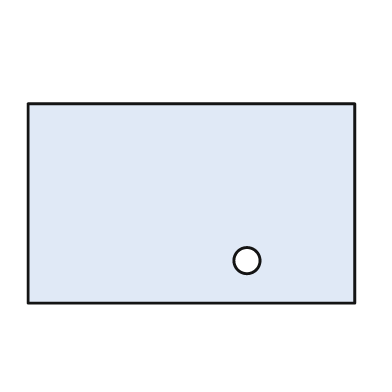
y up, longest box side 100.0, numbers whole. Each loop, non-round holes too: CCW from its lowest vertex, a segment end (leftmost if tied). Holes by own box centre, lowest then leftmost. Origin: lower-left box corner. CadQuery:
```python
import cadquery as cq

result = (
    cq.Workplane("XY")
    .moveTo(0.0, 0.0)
    .lineTo(100.0, 0.0)
    .lineTo(100.0, 61.0)
    .lineTo(0.0, 61.0)
    .close()
    .moveTo(67.0, 13.0)
    .circle(4.0)
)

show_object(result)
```